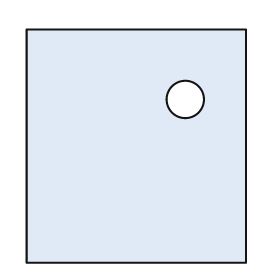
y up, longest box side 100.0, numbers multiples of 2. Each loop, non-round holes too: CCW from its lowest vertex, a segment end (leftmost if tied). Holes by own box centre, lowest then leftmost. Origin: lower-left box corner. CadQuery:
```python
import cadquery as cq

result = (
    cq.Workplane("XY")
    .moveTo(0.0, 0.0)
    .lineTo(94.0, 0.0)
    .lineTo(94.0, 100.0)
    .lineTo(0.0, 100.0)
    .close()
    .moveTo(68.0, 70.0)
    .circle(8.0)
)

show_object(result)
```